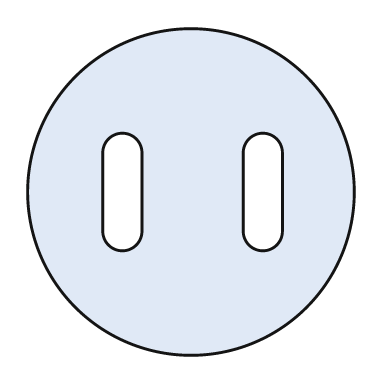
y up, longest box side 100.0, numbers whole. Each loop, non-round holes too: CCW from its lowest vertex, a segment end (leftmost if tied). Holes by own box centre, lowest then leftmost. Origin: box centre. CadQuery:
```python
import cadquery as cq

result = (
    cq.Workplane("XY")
    .moveTo(0.0, 0.0)
    .circle(50.0)
    .moveTo(-27.0, -12.0)
    .threePointArc((-21.0, -18.0), (-15.0, -12.0))
    .lineTo(-15.0, 12.0)
    .threePointArc((-21.0, 18.0), (-27.0, 12.0))
    .close()
    .moveTo(16.0, -12.0)
    .threePointArc((22.0, -18.0), (28.0, -12.0))
    .lineTo(28.0, 12.0)
    .threePointArc((22.0, 18.0), (16.0, 12.0))
    .close()
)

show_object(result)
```